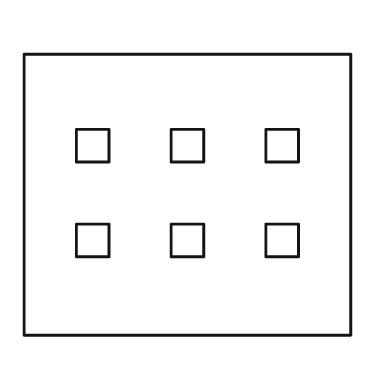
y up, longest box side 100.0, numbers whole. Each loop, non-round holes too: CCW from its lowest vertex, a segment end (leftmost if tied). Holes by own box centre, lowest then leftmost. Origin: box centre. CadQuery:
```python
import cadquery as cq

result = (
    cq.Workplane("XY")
    .moveTo(-50.0, -43.0)
    .lineTo(50.0, -43.0)
    .lineTo(50.0, 43.0)
    .lineTo(-50.0, 43.0)
    .close()
    .moveTo(-34.0, -19.0)
    .lineTo(-24.0, -19.0)
    .lineTo(-24.0, -9.0)
    .lineTo(-34.0, -9.0)
    .close()
    .moveTo(-5.0, -19.0)
    .lineTo(5.0, -19.0)
    .lineTo(5.0, -9.0)
    .lineTo(-5.0, -9.0)
    .close()
    .moveTo(24.0, -19.0)
    .lineTo(34.0, -19.0)
    .lineTo(34.0, -9.0)
    .lineTo(24.0, -9.0)
    .close()
    .moveTo(-34.0, 10.0)
    .lineTo(-24.0, 10.0)
    .lineTo(-24.0, 20.0)
    .lineTo(-34.0, 20.0)
    .close()
    .moveTo(-5.0, 10.0)
    .lineTo(5.0, 10.0)
    .lineTo(5.0, 20.0)
    .lineTo(-5.0, 20.0)
    .close()
    .moveTo(24.0, 10.0)
    .lineTo(34.0, 10.0)
    .lineTo(34.0, 20.0)
    .lineTo(24.0, 20.0)
    .close()
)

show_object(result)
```